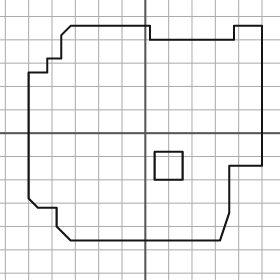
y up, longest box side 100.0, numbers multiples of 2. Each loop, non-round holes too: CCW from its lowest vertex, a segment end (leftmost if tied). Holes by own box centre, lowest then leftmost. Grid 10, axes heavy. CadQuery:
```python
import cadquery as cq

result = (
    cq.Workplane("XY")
    .moveTo(-32.0, -46.0)
    .lineTo(32.0, -46.0)
    .lineTo(36.0, -34.0)
    .lineTo(36.0, -14.0)
    .lineTo(50.0, -14.0)
    .lineTo(50.0, 46.0)
    .lineTo(38.0, 46.0)
    .lineTo(38.0, 40.0)
    .lineTo(2.0, 40.0)
    .lineTo(2.0, 46.0)
    .lineTo(-32.0, 46.0)
    .lineTo(-36.0, 42.0)
    .lineTo(-36.0, 32.0)
    .lineTo(-42.0, 32.0)
    .lineTo(-42.0, 26.0)
    .lineTo(-50.0, 26.0)
    .lineTo(-50.0, -28.0)
    .lineTo(-46.0, -32.0)
    .lineTo(-38.0, -32.0)
    .lineTo(-38.0, -40.0)
    .close()
    .moveTo(4.0, -20.0)
    .lineTo(16.0, -20.0)
    .lineTo(16.0, -8.0)
    .lineTo(4.0, -8.0)
    .close()
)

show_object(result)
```